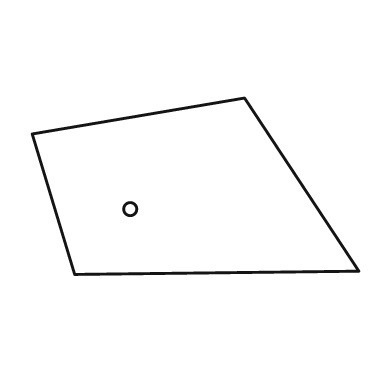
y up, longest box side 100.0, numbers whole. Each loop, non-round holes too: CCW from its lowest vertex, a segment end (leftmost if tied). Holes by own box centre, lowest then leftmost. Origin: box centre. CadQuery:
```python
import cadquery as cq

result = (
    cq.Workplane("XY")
    .moveTo(-37.0, -27.0)
    .lineTo(50.0, -26.0)
    .lineTo(15.0, 27.0)
    .lineTo(-50.0, 16.0)
    .close()
    .moveTo(-20.0, -7.0)
    .circle(2.0)
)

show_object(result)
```